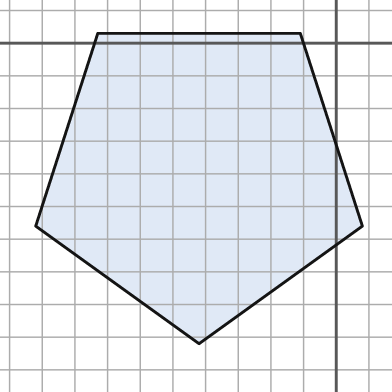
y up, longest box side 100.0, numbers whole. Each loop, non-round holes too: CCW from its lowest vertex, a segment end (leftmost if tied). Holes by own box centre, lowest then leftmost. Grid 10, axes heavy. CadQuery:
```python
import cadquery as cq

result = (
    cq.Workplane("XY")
    .moveTo(-42.0, -92.0)
    .lineTo(8.0, -56.0)
    .lineTo(-11.0, 3.0)
    .lineTo(-73.0, 3.0)
    .lineTo(-92.0, -56.0)
    .close()
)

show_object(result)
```